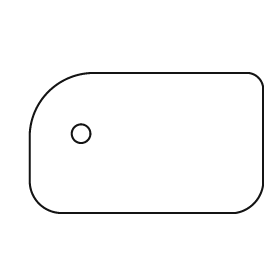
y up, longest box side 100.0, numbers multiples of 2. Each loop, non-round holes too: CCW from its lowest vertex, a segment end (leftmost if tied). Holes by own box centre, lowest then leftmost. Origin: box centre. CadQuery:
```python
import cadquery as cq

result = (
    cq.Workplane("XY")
    .moveTo(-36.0, -30.0)
    .lineTo(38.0, -30.0)
    .threePointArc((46.0, -26.0), (50.0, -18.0))
    .lineTo(50.0, 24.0)
    .threePointArc((48.0, 28.0), (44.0, 30.0))
    .lineTo(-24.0, 30.0)
    .threePointArc((-42.0, 22.0), (-50.0, 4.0))
    .lineTo(-50.0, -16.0)
    .threePointArc((-46.0, -26.0), (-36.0, -30.0))
    .close()
    .moveTo(-28.0, 4.0)
    .circle(4.0)
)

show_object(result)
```